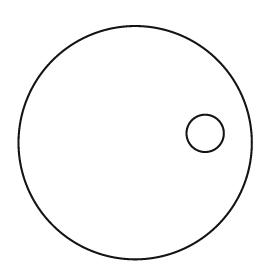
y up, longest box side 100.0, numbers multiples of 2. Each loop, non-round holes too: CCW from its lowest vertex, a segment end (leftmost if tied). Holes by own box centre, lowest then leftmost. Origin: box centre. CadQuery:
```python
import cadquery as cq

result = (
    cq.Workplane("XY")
    .moveTo(0.0, 0.0)
    .circle(50.0)
    .moveTo(30.0, 4.0)
    .circle(8.0)
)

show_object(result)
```